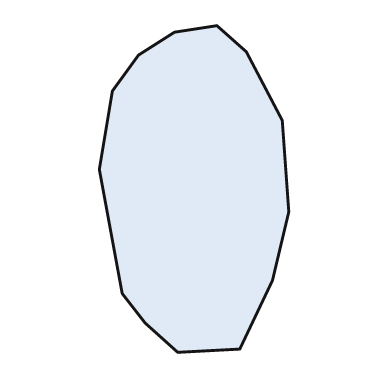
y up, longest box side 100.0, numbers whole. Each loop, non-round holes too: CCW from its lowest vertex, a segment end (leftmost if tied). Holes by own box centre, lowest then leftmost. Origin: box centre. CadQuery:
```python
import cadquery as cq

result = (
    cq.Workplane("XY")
    .moveTo(-5.0, -50.0)
    .lineTo(14.0, -49.0)
    .lineTo(24.0, -28.0)
    .lineTo(29.0, -7.0)
    .lineTo(27.0, 21.0)
    .lineTo(16.0, 42.0)
    .lineTo(7.0, 50.0)
    .lineTo(-6.0, 48.0)
    .lineTo(-17.0, 41.0)
    .lineTo(-25.0, 30.0)
    .lineTo(-29.0, 6.0)
    .lineTo(-22.0, -32.0)
    .lineTo(-15.0, -41.0)
    .close()
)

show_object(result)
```